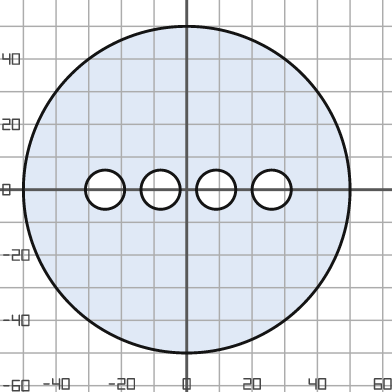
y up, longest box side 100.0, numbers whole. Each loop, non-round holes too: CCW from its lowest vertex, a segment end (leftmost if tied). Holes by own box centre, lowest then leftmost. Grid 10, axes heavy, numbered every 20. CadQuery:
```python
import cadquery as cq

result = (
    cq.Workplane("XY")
    .moveTo(0.0, 0.0)
    .circle(50.0)
    .moveTo(-25.0, 0.0)
    .circle(6.0)
    .moveTo(-8.0, 0.0)
    .circle(6.0)
    .moveTo(9.0, 0.0)
    .circle(6.0)
    .moveTo(26.0, 0.0)
    .circle(6.0)
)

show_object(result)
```